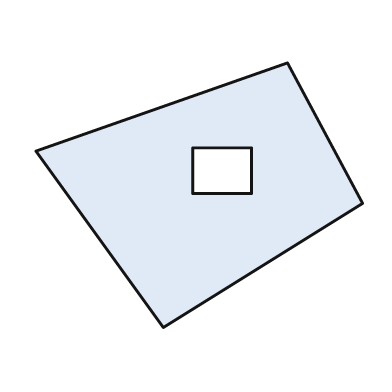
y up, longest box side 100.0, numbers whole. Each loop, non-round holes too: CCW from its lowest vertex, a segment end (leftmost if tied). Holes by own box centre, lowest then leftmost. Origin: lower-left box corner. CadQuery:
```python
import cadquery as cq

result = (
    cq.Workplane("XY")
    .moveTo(39.0, 0.0)
    .lineTo(100.0, 38.0)
    .lineTo(77.0, 81.0)
    .lineTo(0.0, 54.0)
    .close()
    .moveTo(48.0, 41.0)
    .lineTo(66.0, 41.0)
    .lineTo(66.0, 55.0)
    .lineTo(48.0, 55.0)
    .close()
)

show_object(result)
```